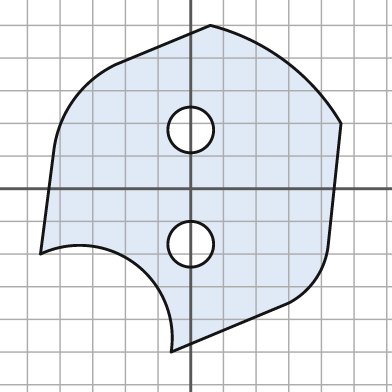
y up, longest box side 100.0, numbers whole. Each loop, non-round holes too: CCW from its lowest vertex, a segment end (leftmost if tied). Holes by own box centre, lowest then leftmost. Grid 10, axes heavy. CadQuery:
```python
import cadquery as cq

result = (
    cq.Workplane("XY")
    .moveTo(-6.0, -50.0)
    .lineTo(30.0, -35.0)
    .threePointArc((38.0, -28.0), (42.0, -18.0))
    .lineTo(46.0, 20.0)
    .threePointArc((29.0, 39.0), (6.0, 50.0))
    .lineTo(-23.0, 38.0)
    .threePointArc((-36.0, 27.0), (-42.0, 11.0))
    .lineTo(-46.0, -20.0)
    .threePointArc((-17.0, -23.0), (-6.0, -50.0))
    .close()
    .moveTo(0.0, -17.0)
    .circle(7.0)
    .moveTo(0.0, 18.0)
    .circle(7.0)
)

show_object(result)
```